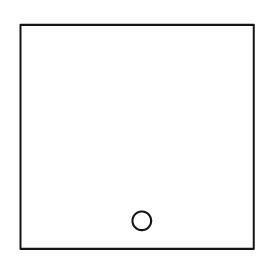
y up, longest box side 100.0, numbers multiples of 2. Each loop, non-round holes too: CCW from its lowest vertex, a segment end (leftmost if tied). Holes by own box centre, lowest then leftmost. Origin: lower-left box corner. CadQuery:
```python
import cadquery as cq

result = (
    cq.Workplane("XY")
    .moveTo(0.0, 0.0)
    .lineTo(100.0, 0.0)
    .lineTo(100.0, 96.0)
    .lineTo(0.0, 96.0)
    .close()
    .moveTo(52.0, 12.0)
    .circle(4.0)
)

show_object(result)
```